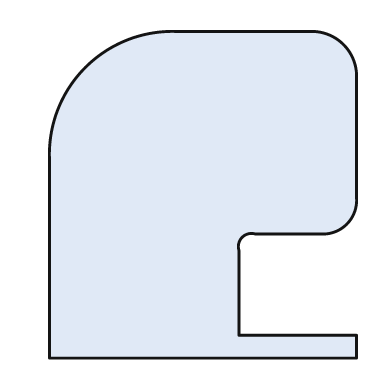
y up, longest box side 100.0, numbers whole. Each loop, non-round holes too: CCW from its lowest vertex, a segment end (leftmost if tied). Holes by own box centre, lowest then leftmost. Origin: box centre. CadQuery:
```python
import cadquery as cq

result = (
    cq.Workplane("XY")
    .moveTo(-47.0, -50.0)
    .lineTo(47.0, -50.0)
    .lineTo(47.0, -43.0)
    .lineTo(11.0, -43.0)
    .lineTo(11.0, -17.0)
    .threePointArc((12.0, -13.0), (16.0, -12.0))
    .lineTo(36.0, -12.0)
    .threePointArc((44.0, -9.0), (47.0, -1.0))
    .lineTo(47.0, 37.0)
    .threePointArc((43.0, 46.0), (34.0, 50.0))
    .lineTo(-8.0, 50.0)
    .threePointArc((-36.0, 39.0), (-47.0, 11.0))
    .close()
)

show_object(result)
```